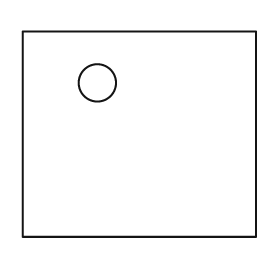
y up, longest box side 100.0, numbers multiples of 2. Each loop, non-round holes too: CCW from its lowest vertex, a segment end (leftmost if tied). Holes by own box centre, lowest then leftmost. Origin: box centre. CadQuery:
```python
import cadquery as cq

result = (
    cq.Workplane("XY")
    .moveTo(-50.0, -44.0)
    .lineTo(50.0, -44.0)
    .lineTo(50.0, 44.0)
    .lineTo(-50.0, 44.0)
    .close()
    .moveTo(-18.0, 22.0)
    .circle(8.0)
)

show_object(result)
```